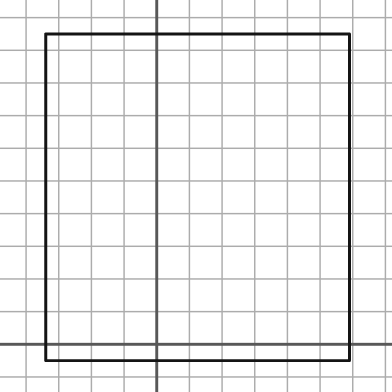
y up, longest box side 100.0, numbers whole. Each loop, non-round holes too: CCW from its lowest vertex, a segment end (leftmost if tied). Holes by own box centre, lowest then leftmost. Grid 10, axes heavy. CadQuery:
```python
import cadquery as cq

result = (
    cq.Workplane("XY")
    .moveTo(-34.0, -5.0)
    .lineTo(59.0, -5.0)
    .lineTo(59.0, 95.0)
    .lineTo(-34.0, 95.0)
    .close()
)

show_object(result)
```